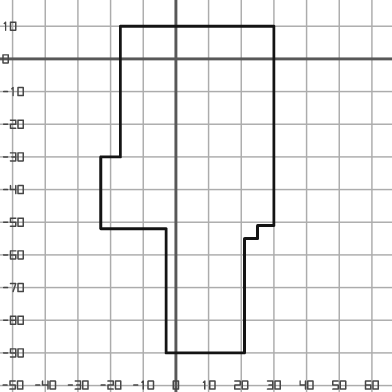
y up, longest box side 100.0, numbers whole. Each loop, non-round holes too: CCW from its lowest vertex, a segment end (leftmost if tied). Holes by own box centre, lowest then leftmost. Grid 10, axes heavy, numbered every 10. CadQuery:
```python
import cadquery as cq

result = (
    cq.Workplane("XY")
    .moveTo(-3.0, -90.0)
    .lineTo(21.0, -90.0)
    .lineTo(21.0, -55.0)
    .lineTo(25.0, -55.0)
    .lineTo(25.0, -51.0)
    .lineTo(30.0, -51.0)
    .lineTo(30.0, 10.0)
    .lineTo(-17.0, 10.0)
    .lineTo(-17.0, -30.0)
    .lineTo(-23.0, -30.0)
    .lineTo(-23.0, -52.0)
    .lineTo(-3.0, -52.0)
    .close()
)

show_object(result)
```